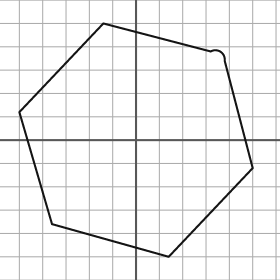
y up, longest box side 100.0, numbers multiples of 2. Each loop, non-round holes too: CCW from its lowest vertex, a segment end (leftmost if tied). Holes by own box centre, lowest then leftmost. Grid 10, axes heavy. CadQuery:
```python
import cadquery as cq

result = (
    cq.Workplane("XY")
    .moveTo(14.0, -50.0)
    .lineTo(50.0, -12.0)
    .lineTo(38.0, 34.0)
    .threePointArc((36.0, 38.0), (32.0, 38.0))
    .lineTo(-14.0, 50.0)
    .lineTo(-50.0, 12.0)
    .lineTo(-36.0, -36.0)
    .close()
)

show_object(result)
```